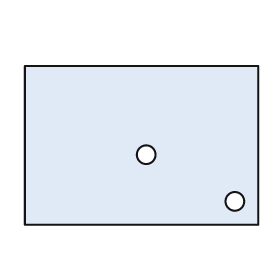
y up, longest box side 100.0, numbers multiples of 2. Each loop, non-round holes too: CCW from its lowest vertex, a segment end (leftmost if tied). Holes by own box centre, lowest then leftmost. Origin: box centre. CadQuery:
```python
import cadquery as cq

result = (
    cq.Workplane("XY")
    .moveTo(-50.0, -34.0)
    .lineTo(50.0, -34.0)
    .lineTo(50.0, 34.0)
    .lineTo(-50.0, 34.0)
    .close()
    .moveTo(40.0, -24.0)
    .circle(4.0)
    .moveTo(2.0, -4.0)
    .circle(4.0)
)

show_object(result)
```